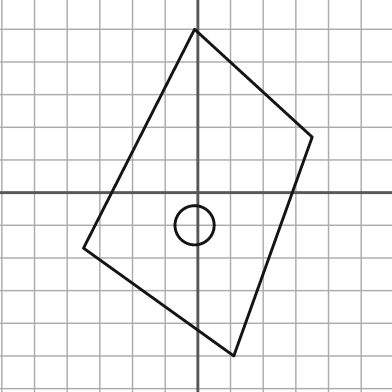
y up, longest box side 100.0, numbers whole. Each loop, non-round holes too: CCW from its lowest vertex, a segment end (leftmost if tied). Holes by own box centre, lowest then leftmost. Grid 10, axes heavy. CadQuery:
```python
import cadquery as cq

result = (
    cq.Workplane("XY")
    .moveTo(11.0, -50.0)
    .lineTo(35.0, 17.0)
    .lineTo(-1.0, 50.0)
    .lineTo(-35.0, -17.0)
    .close()
    .moveTo(-1.0, -10.0)
    .circle(6.0)
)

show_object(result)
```